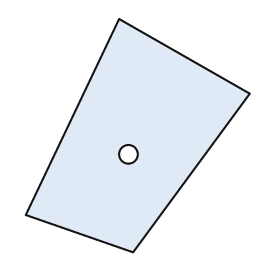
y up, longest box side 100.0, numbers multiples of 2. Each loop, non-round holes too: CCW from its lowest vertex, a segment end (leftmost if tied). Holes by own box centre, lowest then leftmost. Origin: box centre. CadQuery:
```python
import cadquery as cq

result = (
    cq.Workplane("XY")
    .moveTo(-2.0, -50.0)
    .lineTo(48.0, 18.0)
    .lineTo(-8.0, 50.0)
    .lineTo(-48.0, -34.0)
    .close()
    .moveTo(-4.0, -8.0)
    .circle(4.0)
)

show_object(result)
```